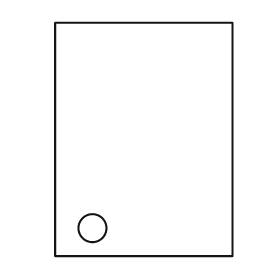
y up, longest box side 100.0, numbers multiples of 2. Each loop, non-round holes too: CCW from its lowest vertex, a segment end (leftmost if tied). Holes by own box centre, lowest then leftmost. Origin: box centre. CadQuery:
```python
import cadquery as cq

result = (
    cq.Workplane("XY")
    .moveTo(-38.0, -50.0)
    .lineTo(38.0, -50.0)
    .lineTo(38.0, 50.0)
    .lineTo(-38.0, 50.0)
    .close()
    .moveTo(-22.0, -38.0)
    .circle(6.0)
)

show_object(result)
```